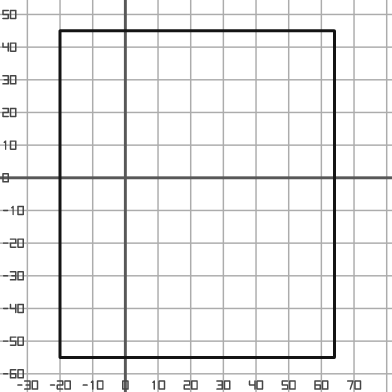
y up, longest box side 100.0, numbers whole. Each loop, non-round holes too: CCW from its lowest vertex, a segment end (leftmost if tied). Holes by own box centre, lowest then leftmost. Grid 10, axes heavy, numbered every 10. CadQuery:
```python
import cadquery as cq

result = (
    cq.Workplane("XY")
    .moveTo(-20.0, -55.0)
    .lineTo(64.0, -55.0)
    .lineTo(64.0, 45.0)
    .lineTo(-20.0, 45.0)
    .close()
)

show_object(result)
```